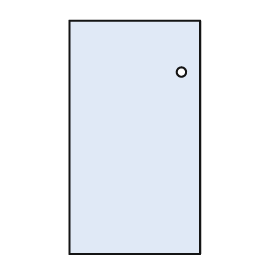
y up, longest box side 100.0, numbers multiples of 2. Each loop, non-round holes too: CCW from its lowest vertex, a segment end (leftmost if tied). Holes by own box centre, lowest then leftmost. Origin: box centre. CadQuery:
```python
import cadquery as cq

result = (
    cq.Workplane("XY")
    .moveTo(-28.0, -50.0)
    .lineTo(28.0, -50.0)
    .lineTo(28.0, 50.0)
    .lineTo(-28.0, 50.0)
    .close()
    .moveTo(20.0, 28.0)
    .circle(2.0)
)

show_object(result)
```